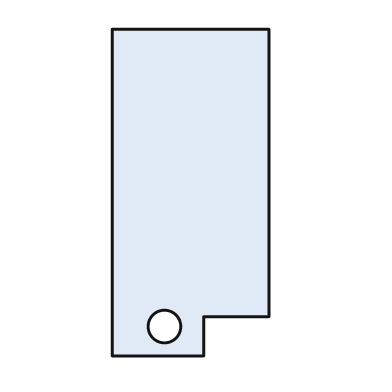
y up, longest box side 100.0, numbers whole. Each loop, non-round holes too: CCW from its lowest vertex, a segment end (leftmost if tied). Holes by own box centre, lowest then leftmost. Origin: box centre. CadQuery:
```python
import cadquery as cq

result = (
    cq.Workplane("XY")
    .moveTo(-24.0, -50.0)
    .lineTo(4.0, -50.0)
    .lineTo(4.0, -38.0)
    .lineTo(24.0, -38.0)
    .lineTo(24.0, 50.0)
    .lineTo(-24.0, 50.0)
    .close()
    .moveTo(-8.0, -41.0)
    .circle(5.0)
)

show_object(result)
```